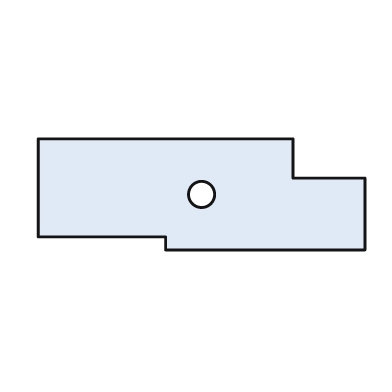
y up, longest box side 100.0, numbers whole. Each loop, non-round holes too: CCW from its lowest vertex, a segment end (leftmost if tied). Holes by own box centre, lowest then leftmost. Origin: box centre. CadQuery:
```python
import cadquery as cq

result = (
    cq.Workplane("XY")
    .moveTo(-11.0, -17.0)
    .lineTo(50.0, -17.0)
    .lineTo(50.0, 5.0)
    .lineTo(28.0, 5.0)
    .lineTo(28.0, 17.0)
    .lineTo(-50.0, 17.0)
    .lineTo(-50.0, -13.0)
    .lineTo(-11.0, -13.0)
    .close()
    .moveTo(0.0, 0.0)
    .circle(4.0)
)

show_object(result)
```